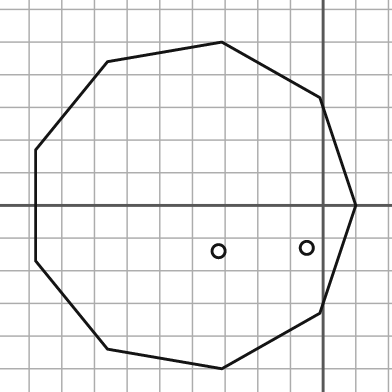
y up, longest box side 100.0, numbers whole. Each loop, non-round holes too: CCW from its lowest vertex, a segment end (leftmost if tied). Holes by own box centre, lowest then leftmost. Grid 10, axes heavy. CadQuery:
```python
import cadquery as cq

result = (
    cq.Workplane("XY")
    .moveTo(-31.0, -50.0)
    .lineTo(-1.0, -33.0)
    .lineTo(10.0, 0.0)
    .lineTo(-1.0, 33.0)
    .lineTo(-31.0, 50.0)
    .lineTo(-66.0, 44.0)
    .lineTo(-88.0, 17.0)
    .lineTo(-88.0, -17.0)
    .lineTo(-66.0, -44.0)
    .close()
    .moveTo(-32.0, -14.0)
    .circle(2.0)
    .moveTo(-5.0, -13.0)
    .circle(2.0)
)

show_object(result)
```